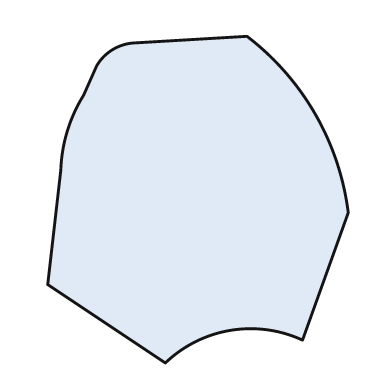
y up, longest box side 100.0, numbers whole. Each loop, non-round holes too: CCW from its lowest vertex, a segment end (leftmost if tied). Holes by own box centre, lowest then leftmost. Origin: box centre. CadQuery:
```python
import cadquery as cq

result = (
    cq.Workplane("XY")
    .moveTo(-10.0, -50.0)
    .threePointArc((10.0, -40.0), (32.0, -43.0))
    .lineTo(46.0, -4.0)
    .threePointArc((36.0, 26.0), (15.0, 50.0))
    .lineTo(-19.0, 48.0)
    .threePointArc((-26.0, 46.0), (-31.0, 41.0))
    .lineTo(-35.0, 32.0)
    .threePointArc((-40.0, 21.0), (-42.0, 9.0))
    .lineTo(-46.0, -26.0)
    .close()
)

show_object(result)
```